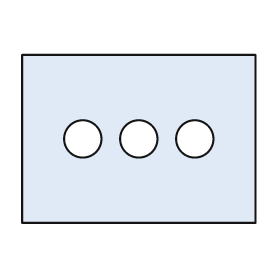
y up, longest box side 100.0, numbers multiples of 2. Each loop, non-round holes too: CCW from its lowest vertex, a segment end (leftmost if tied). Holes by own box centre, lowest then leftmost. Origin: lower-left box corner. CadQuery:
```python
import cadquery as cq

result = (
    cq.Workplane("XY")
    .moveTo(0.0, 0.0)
    .lineTo(100.0, 0.0)
    .lineTo(100.0, 72.0)
    .lineTo(0.0, 72.0)
    .close()
    .moveTo(26.0, 36.0)
    .circle(8.0)
    .moveTo(50.0, 36.0)
    .circle(8.0)
    .moveTo(74.0, 36.0)
    .circle(8.0)
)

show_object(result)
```